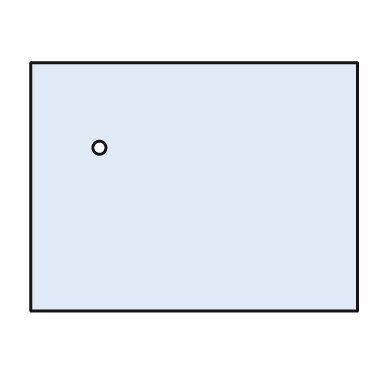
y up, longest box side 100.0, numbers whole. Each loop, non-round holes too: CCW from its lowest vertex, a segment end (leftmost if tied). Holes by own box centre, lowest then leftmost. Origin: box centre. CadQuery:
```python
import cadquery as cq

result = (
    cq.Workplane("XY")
    .moveTo(-50.0, -38.0)
    .lineTo(50.0, -38.0)
    .lineTo(50.0, 38.0)
    .lineTo(-50.0, 38.0)
    .close()
    .moveTo(-29.0, 12.0)
    .circle(2.0)
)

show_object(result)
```